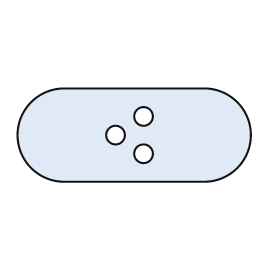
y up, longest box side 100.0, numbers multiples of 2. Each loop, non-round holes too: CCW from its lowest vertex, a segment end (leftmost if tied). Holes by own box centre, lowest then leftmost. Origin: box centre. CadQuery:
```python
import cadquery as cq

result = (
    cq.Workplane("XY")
    .moveTo(-30.0, -20.0)
    .lineTo(30.0, -20.0)
    .threePointArc((50.0, 0.0), (30.0, 20.0))
    .lineTo(-30.0, 20.0)
    .threePointArc((-50.0, 0.0), (-30.0, -20.0))
    .close()
    .moveTo(4.0, -8.0)
    .circle(4.0)
    .moveTo(-8.0, 0.0)
    .circle(4.0)
    .moveTo(4.0, 8.0)
    .circle(4.0)
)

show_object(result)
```